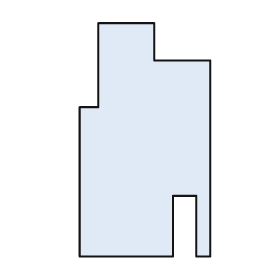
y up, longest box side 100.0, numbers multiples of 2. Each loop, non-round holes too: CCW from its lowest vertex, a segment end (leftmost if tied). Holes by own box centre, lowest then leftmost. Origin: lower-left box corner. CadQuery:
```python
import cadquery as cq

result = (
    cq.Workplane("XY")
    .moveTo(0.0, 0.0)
    .lineTo(40.0, 0.0)
    .lineTo(40.0, 26.0)
    .lineTo(50.0, 26.0)
    .lineTo(50.0, 0.0)
    .lineTo(56.0, 0.0)
    .lineTo(56.0, 84.0)
    .lineTo(32.0, 84.0)
    .lineTo(32.0, 100.0)
    .lineTo(8.0, 100.0)
    .lineTo(8.0, 64.0)
    .lineTo(0.0, 64.0)
    .close()
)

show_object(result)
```